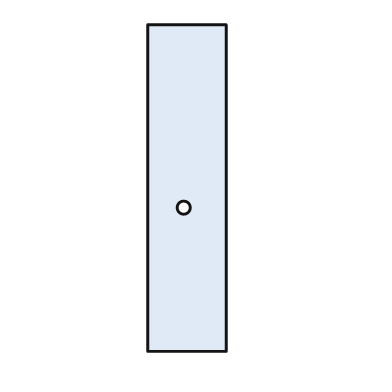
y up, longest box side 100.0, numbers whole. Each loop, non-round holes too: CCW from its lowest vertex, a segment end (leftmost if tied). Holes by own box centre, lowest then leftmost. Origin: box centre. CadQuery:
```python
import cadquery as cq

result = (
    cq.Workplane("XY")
    .moveTo(-12.0, -50.0)
    .lineTo(12.0, -50.0)
    .lineTo(12.0, 50.0)
    .lineTo(-12.0, 50.0)
    .close()
    .moveTo(-1.0, -6.0)
    .circle(2.0)
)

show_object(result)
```